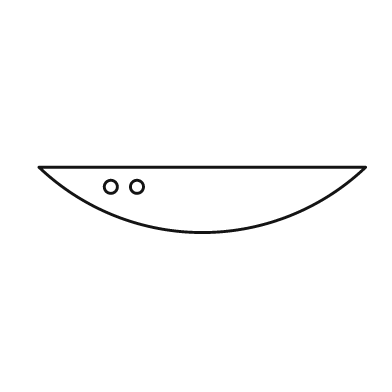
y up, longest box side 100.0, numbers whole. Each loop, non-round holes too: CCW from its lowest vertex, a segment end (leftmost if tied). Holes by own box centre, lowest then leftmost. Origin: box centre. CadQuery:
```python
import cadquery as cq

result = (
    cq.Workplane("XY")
    .moveTo(-50.0, 10.0)
    .threePointArc((0.0, -10.0), (50.0, 10.0))
    .close()
    .moveTo(-28.0, 4.0)
    .circle(2.0)
    .moveTo(-20.0, 4.0)
    .circle(2.0)
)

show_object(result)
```